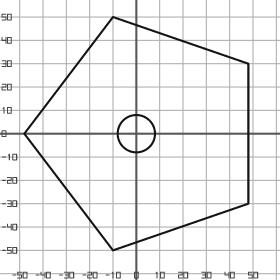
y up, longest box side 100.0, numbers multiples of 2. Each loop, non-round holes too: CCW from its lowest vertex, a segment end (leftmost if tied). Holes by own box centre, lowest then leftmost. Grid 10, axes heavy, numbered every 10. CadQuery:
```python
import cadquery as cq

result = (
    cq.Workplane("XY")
    .moveTo(-10.0, -50.0)
    .lineTo(48.0, -30.0)
    .lineTo(48.0, 30.0)
    .lineTo(-10.0, 50.0)
    .lineTo(-48.0, 0.0)
    .close()
    .moveTo(0.0, 0.0)
    .circle(8.0)
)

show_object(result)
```